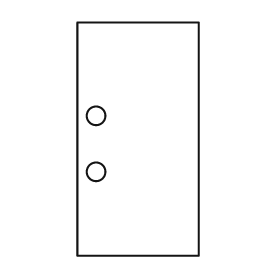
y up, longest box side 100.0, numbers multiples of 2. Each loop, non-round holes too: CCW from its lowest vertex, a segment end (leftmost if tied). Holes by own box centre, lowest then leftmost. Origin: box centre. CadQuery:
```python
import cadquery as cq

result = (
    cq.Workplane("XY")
    .moveTo(-26.0, -50.0)
    .lineTo(26.0, -50.0)
    .lineTo(26.0, 50.0)
    .lineTo(-26.0, 50.0)
    .close()
    .moveTo(-18.0, -14.0)
    .circle(4.0)
    .moveTo(-18.0, 10.0)
    .circle(4.0)
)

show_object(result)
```